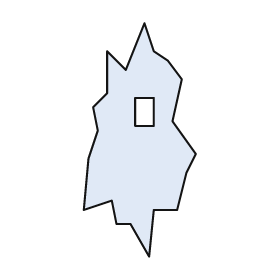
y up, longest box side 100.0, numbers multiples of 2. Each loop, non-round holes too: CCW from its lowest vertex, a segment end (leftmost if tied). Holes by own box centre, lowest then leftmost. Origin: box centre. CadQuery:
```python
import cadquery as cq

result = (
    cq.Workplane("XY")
    .moveTo(4.0, -50.0)
    .lineTo(6.0, -30.0)
    .lineTo(16.0, -30.0)
    .lineTo(20.0, -14.0)
    .lineTo(24.0, -6.0)
    .lineTo(14.0, 8.0)
    .lineTo(18.0, 26.0)
    .lineTo(12.0, 34.0)
    .lineTo(6.0, 38.0)
    .lineTo(2.0, 50.0)
    .lineTo(-6.0, 30.0)
    .lineTo(-14.0, 38.0)
    .lineTo(-14.0, 20.0)
    .lineTo(-20.0, 14.0)
    .lineTo(-18.0, 4.0)
    .lineTo(-22.0, -8.0)
    .lineTo(-24.0, -30.0)
    .lineTo(-12.0, -26.0)
    .lineTo(-10.0, -36.0)
    .lineTo(-4.0, -36.0)
    .close()
    .moveTo(-2.0, 6.0)
    .lineTo(6.0, 6.0)
    .lineTo(6.0, 18.0)
    .lineTo(-2.0, 18.0)
    .close()
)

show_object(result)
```